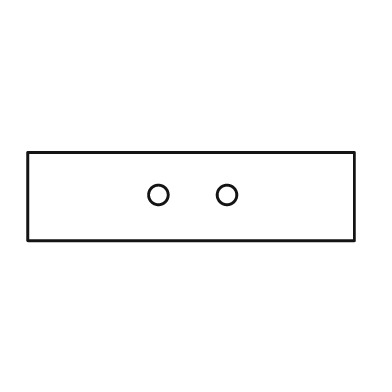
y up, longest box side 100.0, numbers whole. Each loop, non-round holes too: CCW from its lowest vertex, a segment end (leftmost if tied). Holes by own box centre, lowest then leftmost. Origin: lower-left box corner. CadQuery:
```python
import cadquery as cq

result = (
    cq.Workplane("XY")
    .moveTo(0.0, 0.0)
    .lineTo(100.0, 0.0)
    .lineTo(100.0, 27.0)
    .lineTo(0.0, 27.0)
    .close()
    .moveTo(40.0, 14.0)
    .circle(3.0)
    .moveTo(61.0, 14.0)
    .circle(3.0)
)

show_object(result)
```